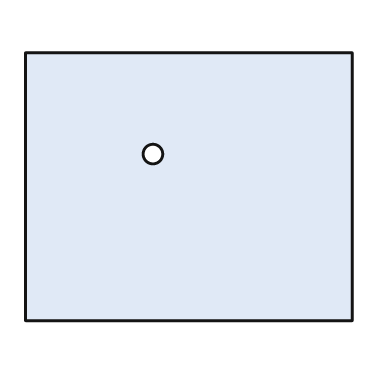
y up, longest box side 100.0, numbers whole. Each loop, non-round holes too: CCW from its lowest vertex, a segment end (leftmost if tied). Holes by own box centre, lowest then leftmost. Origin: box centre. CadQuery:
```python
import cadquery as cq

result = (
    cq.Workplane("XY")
    .moveTo(-50.0, -41.0)
    .lineTo(50.0, -41.0)
    .lineTo(50.0, 41.0)
    .lineTo(-50.0, 41.0)
    .close()
    .moveTo(-11.0, 10.0)
    .circle(3.0)
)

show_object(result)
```